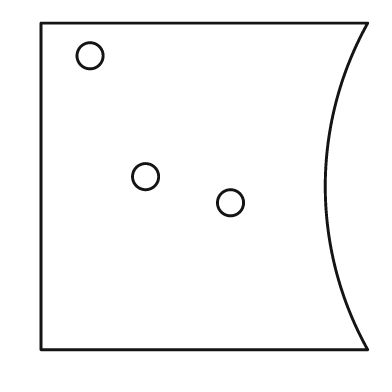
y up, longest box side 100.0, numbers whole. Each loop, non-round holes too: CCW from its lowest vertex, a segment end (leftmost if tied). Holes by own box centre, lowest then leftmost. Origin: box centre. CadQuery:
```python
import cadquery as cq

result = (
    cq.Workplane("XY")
    .moveTo(-50.0, -50.0)
    .lineTo(50.0, -50.0)
    .threePointArc((37.0, 0.0), (50.0, 50.0))
    .lineTo(-50.0, 50.0)
    .close()
    .moveTo(8.0, -5.0)
    .circle(4.0)
    .moveTo(-18.0, 3.0)
    .circle(4.0)
    .moveTo(-35.0, 40.0)
    .circle(4.0)
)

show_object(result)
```